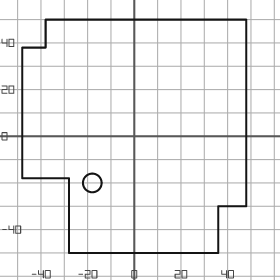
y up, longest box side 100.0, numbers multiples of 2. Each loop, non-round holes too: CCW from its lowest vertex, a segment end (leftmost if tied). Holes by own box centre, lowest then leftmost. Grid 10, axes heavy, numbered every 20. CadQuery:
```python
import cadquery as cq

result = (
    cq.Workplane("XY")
    .moveTo(-28.0, -50.0)
    .lineTo(36.0, -50.0)
    .lineTo(36.0, -30.0)
    .lineTo(48.0, -30.0)
    .lineTo(48.0, 50.0)
    .lineTo(-38.0, 50.0)
    .lineTo(-38.0, 38.0)
    .lineTo(-48.0, 38.0)
    .lineTo(-48.0, -18.0)
    .lineTo(-28.0, -18.0)
    .close()
    .moveTo(-18.0, -20.0)
    .circle(4.0)
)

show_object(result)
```